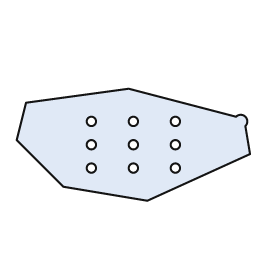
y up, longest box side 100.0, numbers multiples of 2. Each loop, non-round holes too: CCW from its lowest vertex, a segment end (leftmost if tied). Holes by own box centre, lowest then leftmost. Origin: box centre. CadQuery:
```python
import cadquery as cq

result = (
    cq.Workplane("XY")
    .moveTo(6.0, -24.0)
    .lineTo(50.0, -4.0)
    .lineTo(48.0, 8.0)
    .threePointArc((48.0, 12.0), (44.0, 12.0))
    .lineTo(-2.0, 24.0)
    .lineTo(-46.0, 18.0)
    .lineTo(-50.0, 2.0)
    .lineTo(-30.0, -18.0)
    .close()
    .moveTo(-18.0, -10.0)
    .circle(2.0)
    .moveTo(0.0, -10.0)
    .circle(2.0)
    .moveTo(18.0, -10.0)
    .circle(2.0)
    .moveTo(-18.0, 0.0)
    .circle(2.0)
    .moveTo(0.0, 0.0)
    .circle(2.0)
    .moveTo(18.0, 0.0)
    .circle(2.0)
    .moveTo(-18.0, 10.0)
    .circle(2.0)
    .moveTo(0.0, 10.0)
    .circle(2.0)
    .moveTo(18.0, 10.0)
    .circle(2.0)
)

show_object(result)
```